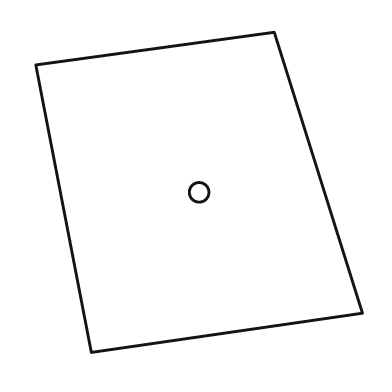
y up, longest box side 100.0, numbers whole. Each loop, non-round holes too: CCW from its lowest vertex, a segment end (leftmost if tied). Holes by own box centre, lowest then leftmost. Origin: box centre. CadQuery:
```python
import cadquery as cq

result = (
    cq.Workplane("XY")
    .moveTo(-33.0, -49.0)
    .lineTo(50.0, -37.0)
    .lineTo(23.0, 49.0)
    .lineTo(-50.0, 39.0)
    .close()
    .moveTo(0.0, 0.0)
    .circle(3.0)
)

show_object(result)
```